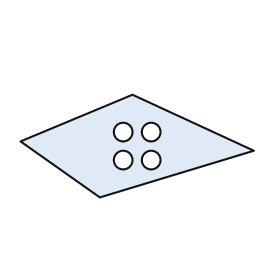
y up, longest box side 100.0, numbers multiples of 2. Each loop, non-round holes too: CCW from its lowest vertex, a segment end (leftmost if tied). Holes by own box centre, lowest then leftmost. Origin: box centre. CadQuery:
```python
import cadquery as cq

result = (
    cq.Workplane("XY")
    .moveTo(-16.0, -22.0)
    .lineTo(50.0, -2.0)
    .lineTo(-2.0, 22.0)
    .lineTo(-50.0, 2.0)
    .close()
    .moveTo(-6.0, -6.0)
    .circle(4.0)
    .moveTo(6.0, -6.0)
    .circle(4.0)
    .moveTo(-6.0, 6.0)
    .circle(4.0)
    .moveTo(6.0, 6.0)
    .circle(4.0)
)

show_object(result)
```